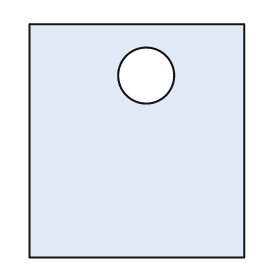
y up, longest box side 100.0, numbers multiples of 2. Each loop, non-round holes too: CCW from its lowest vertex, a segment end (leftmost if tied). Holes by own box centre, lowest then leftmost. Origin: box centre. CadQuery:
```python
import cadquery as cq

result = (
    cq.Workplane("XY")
    .moveTo(-46.0, -50.0)
    .lineTo(46.0, -50.0)
    .lineTo(46.0, 50.0)
    .lineTo(-46.0, 50.0)
    .close()
    .moveTo(4.0, 28.0)
    .circle(12.0)
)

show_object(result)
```